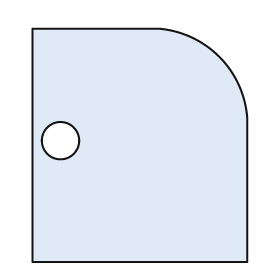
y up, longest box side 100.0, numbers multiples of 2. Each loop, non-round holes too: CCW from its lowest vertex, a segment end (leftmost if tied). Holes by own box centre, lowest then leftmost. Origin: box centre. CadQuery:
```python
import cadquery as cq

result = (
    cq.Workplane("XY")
    .moveTo(-46.0, -50.0)
    .lineTo(46.0, -50.0)
    .lineTo(46.0, 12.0)
    .threePointArc((34.0, 38.0), (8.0, 50.0))
    .lineTo(-46.0, 50.0)
    .close()
    .moveTo(-34.0, 2.0)
    .circle(8.0)
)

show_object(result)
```